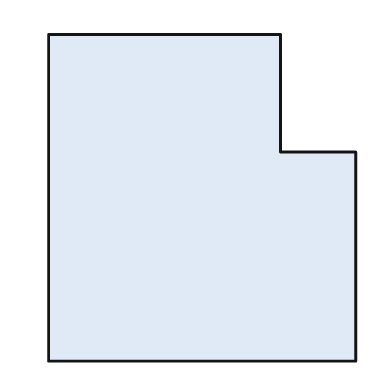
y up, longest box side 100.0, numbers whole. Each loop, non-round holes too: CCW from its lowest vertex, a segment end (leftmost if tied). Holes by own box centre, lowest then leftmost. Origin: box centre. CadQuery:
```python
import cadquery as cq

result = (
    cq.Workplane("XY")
    .moveTo(-47.0, -50.0)
    .lineTo(47.0, -50.0)
    .lineTo(47.0, 14.0)
    .lineTo(24.0, 14.0)
    .lineTo(24.0, 50.0)
    .lineTo(-47.0, 50.0)
    .close()
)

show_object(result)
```